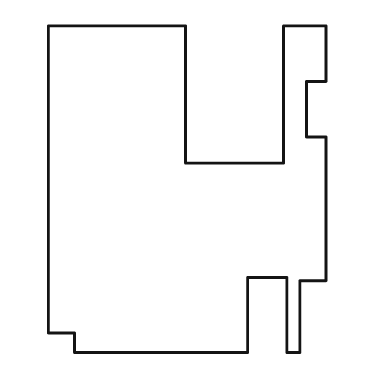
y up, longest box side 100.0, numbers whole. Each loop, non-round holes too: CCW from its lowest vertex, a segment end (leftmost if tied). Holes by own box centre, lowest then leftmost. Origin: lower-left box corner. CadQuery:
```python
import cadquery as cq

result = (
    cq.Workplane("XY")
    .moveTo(8.0, 0.0)
    .lineTo(61.0, 0.0)
    .lineTo(61.0, 23.0)
    .lineTo(73.0, 23.0)
    .lineTo(73.0, 0.0)
    .lineTo(77.0, 0.0)
    .lineTo(77.0, 22.0)
    .lineTo(85.0, 22.0)
    .lineTo(85.0, 66.0)
    .lineTo(79.0, 66.0)
    .lineTo(79.0, 83.0)
    .lineTo(85.0, 83.0)
    .lineTo(85.0, 100.0)
    .lineTo(72.0, 100.0)
    .lineTo(72.0, 58.0)
    .lineTo(42.0, 58.0)
    .lineTo(42.0, 100.0)
    .lineTo(0.0, 100.0)
    .lineTo(0.0, 6.0)
    .lineTo(8.0, 6.0)
    .close()
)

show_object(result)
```